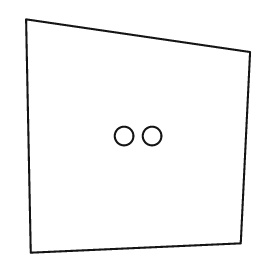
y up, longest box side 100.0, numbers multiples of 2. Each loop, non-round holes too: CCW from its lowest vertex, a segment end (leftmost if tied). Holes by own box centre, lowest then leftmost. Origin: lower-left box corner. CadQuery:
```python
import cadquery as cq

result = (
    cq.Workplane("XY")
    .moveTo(2.0, 0.0)
    .lineTo(92.0, 4.0)
    .lineTo(96.0, 86.0)
    .lineTo(0.0, 100.0)
    .close()
    .moveTo(42.0, 50.0)
    .circle(4.0)
    .moveTo(54.0, 50.0)
    .circle(4.0)
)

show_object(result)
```